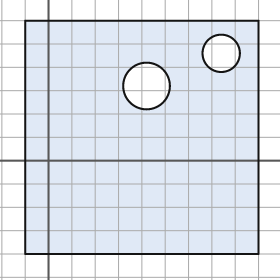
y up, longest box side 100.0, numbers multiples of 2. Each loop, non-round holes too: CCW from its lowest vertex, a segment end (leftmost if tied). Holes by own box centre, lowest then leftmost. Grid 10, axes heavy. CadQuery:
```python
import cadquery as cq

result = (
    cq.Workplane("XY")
    .moveTo(-10.0, -40.0)
    .lineTo(90.0, -40.0)
    .lineTo(90.0, 60.0)
    .lineTo(-10.0, 60.0)
    .close()
    .moveTo(42.0, 32.0)
    .circle(10.0)
    .moveTo(74.0, 46.0)
    .circle(8.0)
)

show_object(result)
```